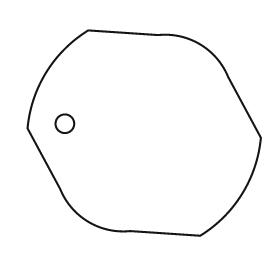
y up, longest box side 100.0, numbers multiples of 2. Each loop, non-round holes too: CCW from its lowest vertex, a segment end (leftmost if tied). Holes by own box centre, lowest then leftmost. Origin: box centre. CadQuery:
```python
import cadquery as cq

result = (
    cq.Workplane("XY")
    .moveTo(24.0, -44.0)
    .threePointArc((42.0, -26.0), (50.0, -2.0))
    .lineTo(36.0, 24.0)
    .threePointArc((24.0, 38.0), (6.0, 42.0))
    .lineTo(-24.0, 44.0)
    .threePointArc((-42.0, 26.0), (-50.0, 2.0))
    .lineTo(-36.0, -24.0)
    .threePointArc((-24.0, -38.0), (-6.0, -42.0))
    .close()
    .moveTo(-34.0, 4.0)
    .circle(4.0)
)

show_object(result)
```